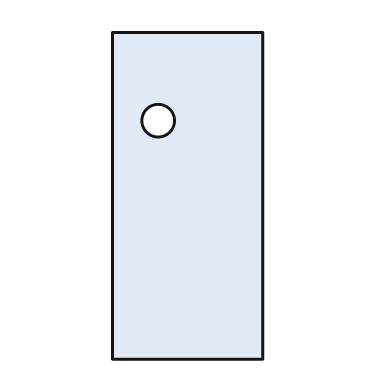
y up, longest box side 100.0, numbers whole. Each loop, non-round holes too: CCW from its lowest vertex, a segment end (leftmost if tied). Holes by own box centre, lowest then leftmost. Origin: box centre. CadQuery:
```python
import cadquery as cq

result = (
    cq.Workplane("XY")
    .moveTo(-23.0, -50.0)
    .lineTo(23.0, -50.0)
    .lineTo(23.0, 50.0)
    .lineTo(-23.0, 50.0)
    .close()
    .moveTo(-9.0, 23.0)
    .circle(5.0)
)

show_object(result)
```